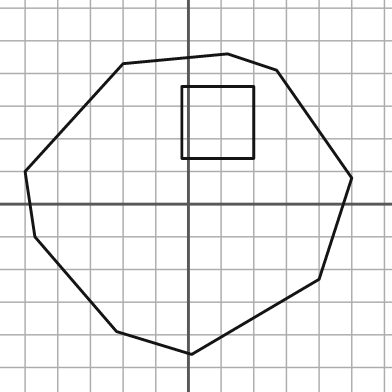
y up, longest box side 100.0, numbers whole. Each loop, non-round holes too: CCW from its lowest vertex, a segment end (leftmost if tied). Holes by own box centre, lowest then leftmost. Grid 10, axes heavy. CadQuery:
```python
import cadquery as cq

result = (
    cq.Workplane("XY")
    .moveTo(1.0, -46.0)
    .lineTo(40.0, -23.0)
    .lineTo(50.0, 8.0)
    .lineTo(27.0, 41.0)
    .lineTo(12.0, 46.0)
    .lineTo(-20.0, 43.0)
    .lineTo(-50.0, 10.0)
    .lineTo(-47.0, -10.0)
    .lineTo(-22.0, -39.0)
    .close()
    .moveTo(-2.0, 14.0)
    .lineTo(20.0, 14.0)
    .lineTo(20.0, 36.0)
    .lineTo(-2.0, 36.0)
    .close()
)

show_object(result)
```